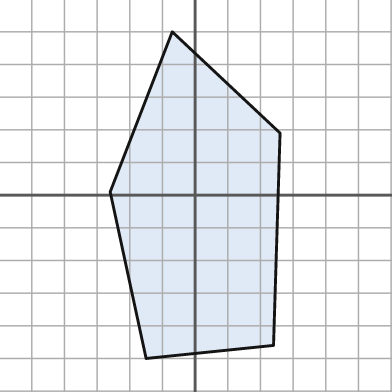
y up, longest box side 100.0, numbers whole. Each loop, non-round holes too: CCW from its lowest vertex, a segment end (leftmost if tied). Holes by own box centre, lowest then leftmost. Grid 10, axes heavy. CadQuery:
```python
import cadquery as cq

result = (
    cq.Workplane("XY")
    .moveTo(-15.0, -50.0)
    .lineTo(24.0, -46.0)
    .lineTo(26.0, 19.0)
    .lineTo(-7.0, 50.0)
    .lineTo(-26.0, 1.0)
    .close()
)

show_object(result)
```